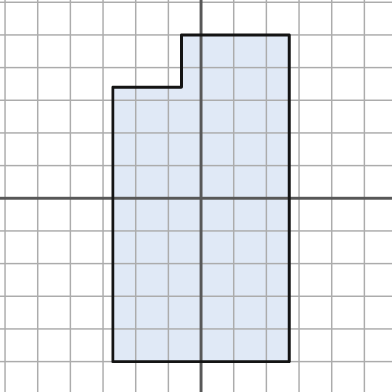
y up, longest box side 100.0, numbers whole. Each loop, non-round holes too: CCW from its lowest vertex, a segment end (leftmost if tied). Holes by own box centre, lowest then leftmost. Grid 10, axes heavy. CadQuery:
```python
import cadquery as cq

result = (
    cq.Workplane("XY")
    .moveTo(-27.0, -50.0)
    .lineTo(27.0, -50.0)
    .lineTo(27.0, 50.0)
    .lineTo(-6.0, 50.0)
    .lineTo(-6.0, 34.0)
    .lineTo(-27.0, 34.0)
    .close()
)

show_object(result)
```